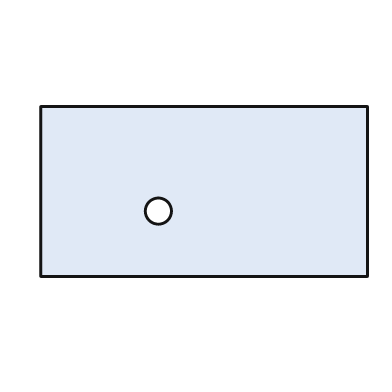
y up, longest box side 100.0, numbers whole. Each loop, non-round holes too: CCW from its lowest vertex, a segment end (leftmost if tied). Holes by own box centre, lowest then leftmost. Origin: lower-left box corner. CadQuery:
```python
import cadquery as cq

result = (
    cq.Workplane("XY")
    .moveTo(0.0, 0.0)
    .lineTo(100.0, 0.0)
    .lineTo(100.0, 52.0)
    .lineTo(0.0, 52.0)
    .close()
    .moveTo(36.0, 20.0)
    .circle(4.0)
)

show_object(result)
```